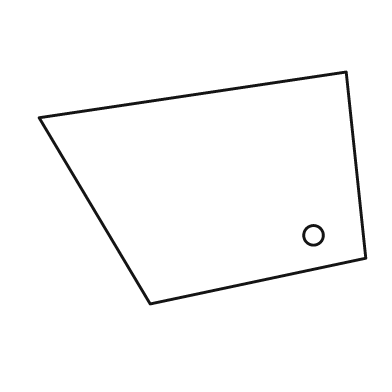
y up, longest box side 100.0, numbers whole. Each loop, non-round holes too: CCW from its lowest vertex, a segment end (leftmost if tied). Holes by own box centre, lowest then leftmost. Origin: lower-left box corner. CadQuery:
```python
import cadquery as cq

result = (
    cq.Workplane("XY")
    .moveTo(34.0, 0.0)
    .lineTo(100.0, 14.0)
    .lineTo(94.0, 71.0)
    .lineTo(0.0, 57.0)
    .close()
    .moveTo(84.0, 21.0)
    .circle(3.0)
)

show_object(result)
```